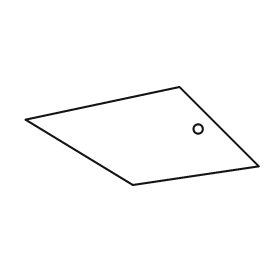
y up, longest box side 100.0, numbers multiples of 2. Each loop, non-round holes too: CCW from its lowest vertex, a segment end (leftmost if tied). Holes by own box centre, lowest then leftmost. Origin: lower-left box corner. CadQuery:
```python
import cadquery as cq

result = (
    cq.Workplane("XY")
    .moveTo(46.0, 0.0)
    .lineTo(100.0, 8.0)
    .lineTo(66.0, 42.0)
    .lineTo(0.0, 28.0)
    .close()
    .moveTo(74.0, 24.0)
    .circle(2.0)
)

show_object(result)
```